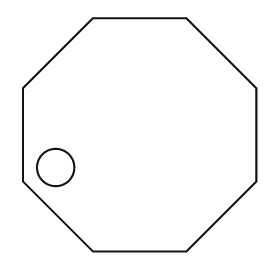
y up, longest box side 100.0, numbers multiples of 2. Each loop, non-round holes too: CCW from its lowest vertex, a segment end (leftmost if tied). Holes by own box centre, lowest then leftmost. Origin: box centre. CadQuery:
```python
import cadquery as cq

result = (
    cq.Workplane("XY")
    .moveTo(-20.0, -50.0)
    .lineTo(20.0, -50.0)
    .lineTo(50.0, -20.0)
    .lineTo(50.0, 20.0)
    .lineTo(20.0, 50.0)
    .lineTo(-20.0, 50.0)
    .lineTo(-50.0, 20.0)
    .lineTo(-50.0, -20.0)
    .close()
    .moveTo(-36.0, -14.0)
    .circle(8.0)
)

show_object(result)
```